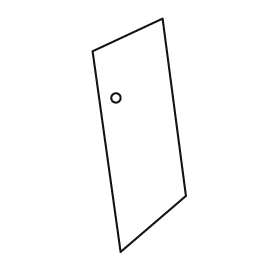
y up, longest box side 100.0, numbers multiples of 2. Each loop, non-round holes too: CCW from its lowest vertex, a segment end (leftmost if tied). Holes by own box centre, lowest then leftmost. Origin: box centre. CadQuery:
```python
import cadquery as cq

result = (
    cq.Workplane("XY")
    .moveTo(-8.0, -50.0)
    .lineTo(20.0, -26.0)
    .lineTo(10.0, 50.0)
    .lineTo(-20.0, 36.0)
    .close()
    .moveTo(-10.0, 16.0)
    .circle(2.0)
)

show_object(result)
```